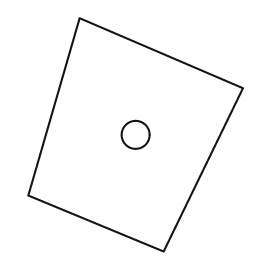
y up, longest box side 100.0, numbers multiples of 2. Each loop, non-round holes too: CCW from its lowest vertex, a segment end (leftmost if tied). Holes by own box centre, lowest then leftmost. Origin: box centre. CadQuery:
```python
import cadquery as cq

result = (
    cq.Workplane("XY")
    .moveTo(12.0, -50.0)
    .lineTo(46.0, 20.0)
    .lineTo(-24.0, 50.0)
    .lineTo(-46.0, -26.0)
    .close()
    .moveTo(0.0, 0.0)
    .circle(6.0)
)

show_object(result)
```